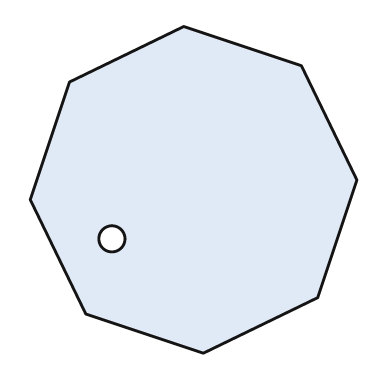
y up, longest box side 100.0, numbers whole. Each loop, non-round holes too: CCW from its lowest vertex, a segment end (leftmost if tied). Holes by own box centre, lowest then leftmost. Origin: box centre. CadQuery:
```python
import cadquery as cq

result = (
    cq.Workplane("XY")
    .moveTo(3.0, -50.0)
    .lineTo(38.0, -33.0)
    .lineTo(50.0, 3.0)
    .lineTo(33.0, 38.0)
    .lineTo(-3.0, 50.0)
    .lineTo(-38.0, 33.0)
    .lineTo(-50.0, -3.0)
    .lineTo(-33.0, -38.0)
    .close()
    .moveTo(-25.0, -15.0)
    .circle(4.0)
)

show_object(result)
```